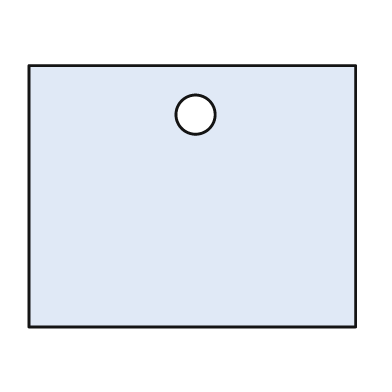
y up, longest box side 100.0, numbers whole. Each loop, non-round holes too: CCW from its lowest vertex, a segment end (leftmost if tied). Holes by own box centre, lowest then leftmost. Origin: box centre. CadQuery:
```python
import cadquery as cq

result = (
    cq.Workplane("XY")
    .moveTo(-50.0, -40.0)
    .lineTo(50.0, -40.0)
    .lineTo(50.0, 40.0)
    .lineTo(-50.0, 40.0)
    .close()
    .moveTo(1.0, 25.0)
    .circle(6.0)
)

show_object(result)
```